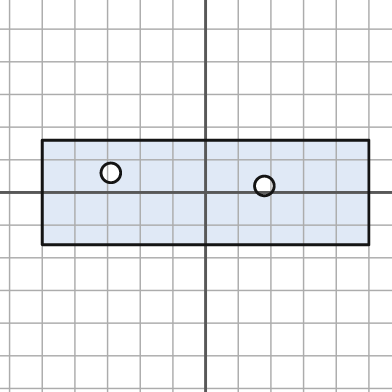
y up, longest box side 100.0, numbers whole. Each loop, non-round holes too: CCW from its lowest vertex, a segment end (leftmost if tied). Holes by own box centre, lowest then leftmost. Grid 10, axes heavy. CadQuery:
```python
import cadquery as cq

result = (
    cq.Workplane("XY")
    .moveTo(-50.0, -16.0)
    .lineTo(50.0, -16.0)
    .lineTo(50.0, 16.0)
    .lineTo(-50.0, 16.0)
    .close()
    .moveTo(18.0, 2.0)
    .circle(3.0)
    .moveTo(-29.0, 6.0)
    .circle(3.0)
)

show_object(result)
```